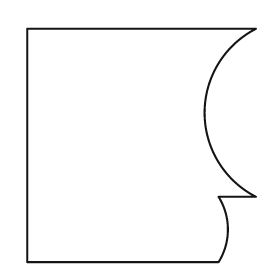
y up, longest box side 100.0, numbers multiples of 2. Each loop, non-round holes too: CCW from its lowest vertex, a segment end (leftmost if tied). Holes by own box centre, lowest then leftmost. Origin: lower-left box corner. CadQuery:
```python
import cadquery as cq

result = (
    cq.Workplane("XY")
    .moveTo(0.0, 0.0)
    .lineTo(82.0, 0.0)
    .threePointArc((86.0, 14.0), (82.0, 28.0))
    .lineTo(98.0, 28.0)
    .threePointArc((76.0, 64.0), (98.0, 100.0))
    .lineTo(0.0, 100.0)
    .close()
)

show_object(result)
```